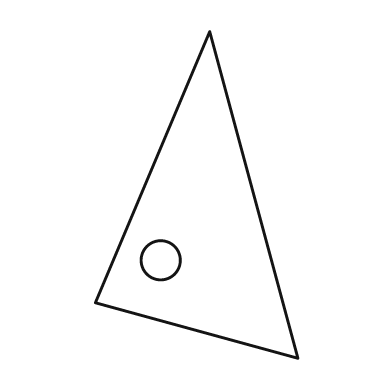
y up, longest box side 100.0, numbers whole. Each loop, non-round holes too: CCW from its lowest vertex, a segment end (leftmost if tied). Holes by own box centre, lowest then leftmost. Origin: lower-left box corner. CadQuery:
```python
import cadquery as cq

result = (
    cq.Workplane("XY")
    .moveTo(62.0, 0.0)
    .lineTo(35.0, 100.0)
    .lineTo(0.0, 17.0)
    .close()
    .moveTo(20.0, 30.0)
    .circle(6.0)
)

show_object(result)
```